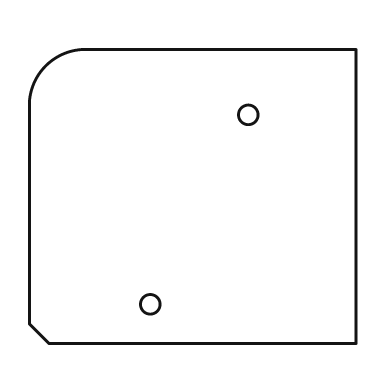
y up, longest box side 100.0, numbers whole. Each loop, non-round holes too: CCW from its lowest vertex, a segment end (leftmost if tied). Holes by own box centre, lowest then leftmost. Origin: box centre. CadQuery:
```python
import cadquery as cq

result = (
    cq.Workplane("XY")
    .moveTo(-44.0, -45.0)
    .lineTo(50.0, -45.0)
    .lineTo(50.0, 45.0)
    .lineTo(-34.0, 45.0)
    .threePointArc((-45.0, 40.0), (-50.0, 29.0))
    .lineTo(-50.0, -39.0)
    .close()
    .moveTo(-13.0, -33.0)
    .circle(3.0)
    .moveTo(17.0, 25.0)
    .circle(3.0)
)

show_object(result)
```